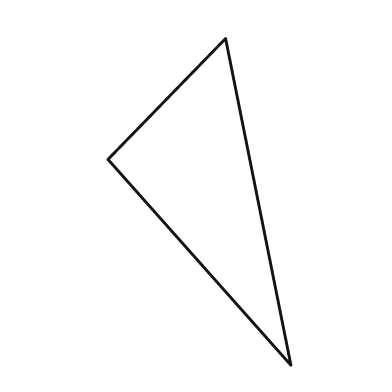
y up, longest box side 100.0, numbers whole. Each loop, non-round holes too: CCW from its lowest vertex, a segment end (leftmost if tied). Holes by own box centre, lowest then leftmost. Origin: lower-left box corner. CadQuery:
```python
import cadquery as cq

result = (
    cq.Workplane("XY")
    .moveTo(56.0, 0.0)
    .lineTo(36.0, 100.0)
    .lineTo(0.0, 63.0)
    .close()
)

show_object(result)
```